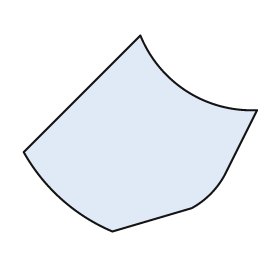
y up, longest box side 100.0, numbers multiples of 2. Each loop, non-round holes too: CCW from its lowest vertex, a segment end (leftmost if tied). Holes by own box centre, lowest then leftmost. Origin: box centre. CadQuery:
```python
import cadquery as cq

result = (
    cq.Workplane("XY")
    .moveTo(-12.0, -42.0)
    .lineTo(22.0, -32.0)
    .threePointArc((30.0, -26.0), (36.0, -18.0))
    .lineTo(50.0, 10.0)
    .threePointArc((20.0, 18.0), (0.0, 42.0))
    .lineTo(-50.0, -8.0)
    .threePointArc((-34.0, -28.0), (-12.0, -42.0))
    .close()
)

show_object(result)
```